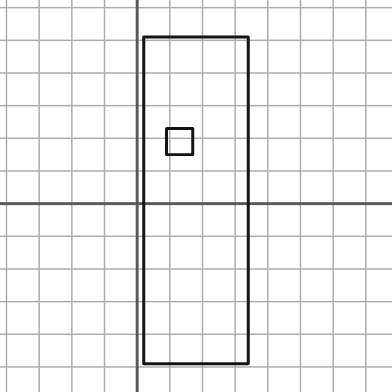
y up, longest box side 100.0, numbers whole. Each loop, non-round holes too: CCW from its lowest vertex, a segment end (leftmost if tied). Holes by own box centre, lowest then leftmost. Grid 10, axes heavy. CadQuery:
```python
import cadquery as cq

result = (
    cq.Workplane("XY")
    .moveTo(2.0, -49.0)
    .lineTo(34.0, -49.0)
    .lineTo(34.0, 51.0)
    .lineTo(2.0, 51.0)
    .close()
    .moveTo(9.0, 15.0)
    .lineTo(17.0, 15.0)
    .lineTo(17.0, 23.0)
    .lineTo(9.0, 23.0)
    .close()
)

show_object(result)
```